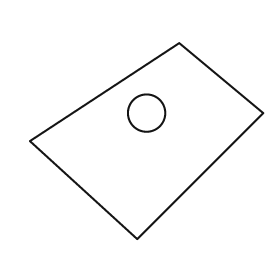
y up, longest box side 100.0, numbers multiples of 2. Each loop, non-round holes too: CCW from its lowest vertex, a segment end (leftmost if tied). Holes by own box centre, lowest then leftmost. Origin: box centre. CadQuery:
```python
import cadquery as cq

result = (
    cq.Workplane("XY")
    .moveTo(-4.0, -42.0)
    .lineTo(50.0, 12.0)
    .lineTo(14.0, 42.0)
    .lineTo(-50.0, 0.0)
    .close()
    .moveTo(0.0, 12.0)
    .circle(8.0)
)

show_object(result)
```